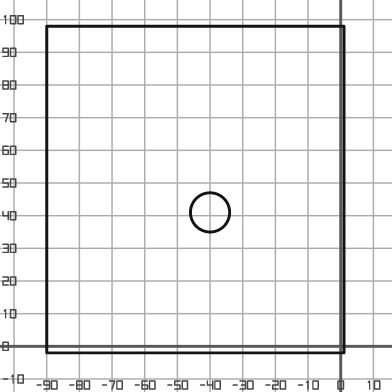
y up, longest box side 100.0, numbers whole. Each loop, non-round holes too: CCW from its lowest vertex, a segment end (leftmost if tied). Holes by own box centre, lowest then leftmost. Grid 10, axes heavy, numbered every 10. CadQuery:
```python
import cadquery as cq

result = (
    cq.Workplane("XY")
    .moveTo(-90.0, -2.0)
    .lineTo(1.0, -2.0)
    .lineTo(1.0, 98.0)
    .lineTo(-90.0, 98.0)
    .close()
    .moveTo(-40.0, 41.0)
    .circle(6.0)
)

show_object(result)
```